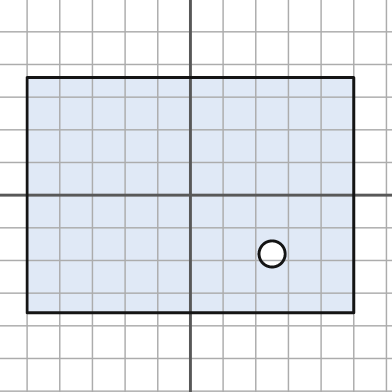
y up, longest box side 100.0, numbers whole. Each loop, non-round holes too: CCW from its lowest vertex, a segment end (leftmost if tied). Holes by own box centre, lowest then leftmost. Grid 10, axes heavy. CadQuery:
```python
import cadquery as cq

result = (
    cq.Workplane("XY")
    .moveTo(-50.0, -36.0)
    .lineTo(50.0, -36.0)
    .lineTo(50.0, 36.0)
    .lineTo(-50.0, 36.0)
    .close()
    .moveTo(25.0, -18.0)
    .circle(4.0)
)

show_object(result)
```